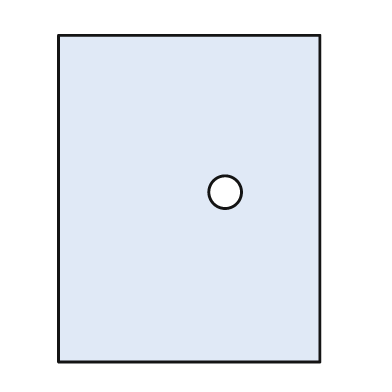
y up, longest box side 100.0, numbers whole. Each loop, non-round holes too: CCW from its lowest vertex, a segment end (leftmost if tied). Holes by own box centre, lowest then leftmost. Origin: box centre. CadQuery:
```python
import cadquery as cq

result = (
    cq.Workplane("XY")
    .moveTo(-40.0, -50.0)
    .lineTo(40.0, -50.0)
    .lineTo(40.0, 50.0)
    .lineTo(-40.0, 50.0)
    .close()
    .moveTo(11.0, 2.0)
    .circle(5.0)
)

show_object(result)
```